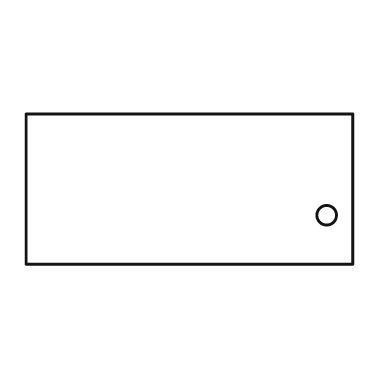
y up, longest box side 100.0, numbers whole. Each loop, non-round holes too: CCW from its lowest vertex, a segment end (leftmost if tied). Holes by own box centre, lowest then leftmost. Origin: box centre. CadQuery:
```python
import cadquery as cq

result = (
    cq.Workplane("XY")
    .moveTo(-50.0, -23.0)
    .lineTo(50.0, -23.0)
    .lineTo(50.0, 23.0)
    .lineTo(-50.0, 23.0)
    .close()
    .moveTo(42.0, -8.0)
    .circle(3.0)
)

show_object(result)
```